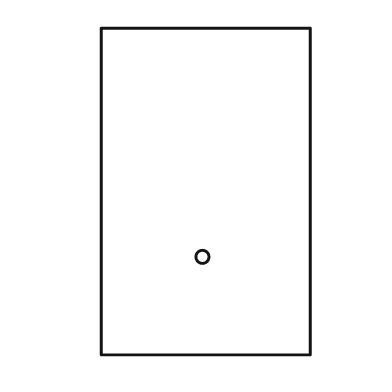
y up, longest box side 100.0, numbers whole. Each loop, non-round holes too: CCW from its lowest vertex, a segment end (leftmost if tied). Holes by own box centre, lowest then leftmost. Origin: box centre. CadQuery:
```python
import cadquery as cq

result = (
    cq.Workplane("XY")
    .moveTo(-32.0, -50.0)
    .lineTo(32.0, -50.0)
    .lineTo(32.0, 50.0)
    .lineTo(-32.0, 50.0)
    .close()
    .moveTo(-1.0, -20.0)
    .circle(2.0)
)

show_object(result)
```